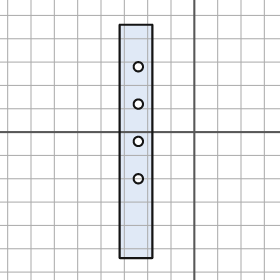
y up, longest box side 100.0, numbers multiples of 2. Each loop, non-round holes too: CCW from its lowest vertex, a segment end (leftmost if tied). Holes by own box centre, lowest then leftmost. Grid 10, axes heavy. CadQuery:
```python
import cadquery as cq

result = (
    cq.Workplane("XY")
    .moveTo(-32.0, -54.0)
    .lineTo(-18.0, -54.0)
    .lineTo(-18.0, 46.0)
    .lineTo(-32.0, 46.0)
    .close()
    .moveTo(-24.0, -20.0)
    .circle(2.0)
    .moveTo(-24.0, -4.0)
    .circle(2.0)
    .moveTo(-24.0, 12.0)
    .circle(2.0)
    .moveTo(-24.0, 28.0)
    .circle(2.0)
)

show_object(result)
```